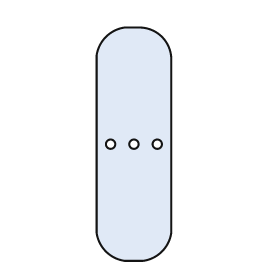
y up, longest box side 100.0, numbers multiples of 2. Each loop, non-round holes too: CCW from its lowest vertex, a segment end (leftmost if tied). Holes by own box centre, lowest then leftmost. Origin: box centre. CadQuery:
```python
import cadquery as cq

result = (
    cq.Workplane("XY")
    .moveTo(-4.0, -50.0)
    .lineTo(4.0, -50.0)
    .threePointArc((12.0, -46.0), (16.0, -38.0))
    .lineTo(16.0, 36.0)
    .threePointArc((12.0, 46.0), (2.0, 50.0))
    .lineTo(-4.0, 50.0)
    .threePointArc((-12.0, 46.0), (-16.0, 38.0))
    .lineTo(-16.0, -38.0)
    .threePointArc((-12.0, -46.0), (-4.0, -50.0))
    .close()
    .moveTo(-10.0, 0.0)
    .circle(2.0)
    .moveTo(0.0, 0.0)
    .circle(2.0)
    .moveTo(10.0, 0.0)
    .circle(2.0)
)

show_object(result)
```